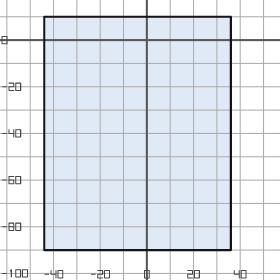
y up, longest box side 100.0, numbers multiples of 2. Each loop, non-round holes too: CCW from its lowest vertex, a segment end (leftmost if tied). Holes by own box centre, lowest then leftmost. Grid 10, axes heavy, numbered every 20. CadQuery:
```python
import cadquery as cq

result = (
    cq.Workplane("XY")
    .moveTo(-44.0, -90.0)
    .lineTo(36.0, -90.0)
    .lineTo(36.0, 10.0)
    .lineTo(-44.0, 10.0)
    .close()
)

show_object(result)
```